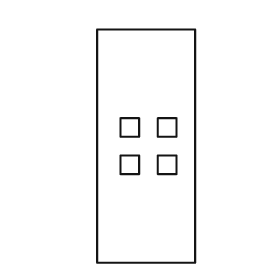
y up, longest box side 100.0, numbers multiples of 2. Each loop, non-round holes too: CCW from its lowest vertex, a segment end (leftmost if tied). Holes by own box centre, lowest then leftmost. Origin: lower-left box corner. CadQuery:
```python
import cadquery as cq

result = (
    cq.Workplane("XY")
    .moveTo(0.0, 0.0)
    .lineTo(42.0, 0.0)
    .lineTo(42.0, 100.0)
    .lineTo(0.0, 100.0)
    .close()
    .moveTo(10.0, 38.0)
    .lineTo(18.0, 38.0)
    .lineTo(18.0, 46.0)
    .lineTo(10.0, 46.0)
    .close()
    .moveTo(26.0, 38.0)
    .lineTo(34.0, 38.0)
    .lineTo(34.0, 46.0)
    .lineTo(26.0, 46.0)
    .close()
    .moveTo(10.0, 54.0)
    .lineTo(18.0, 54.0)
    .lineTo(18.0, 62.0)
    .lineTo(10.0, 62.0)
    .close()
    .moveTo(26.0, 54.0)
    .lineTo(34.0, 54.0)
    .lineTo(34.0, 62.0)
    .lineTo(26.0, 62.0)
    .close()
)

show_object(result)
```